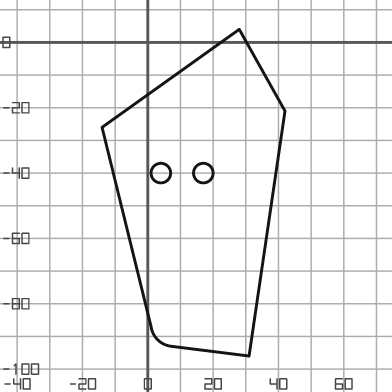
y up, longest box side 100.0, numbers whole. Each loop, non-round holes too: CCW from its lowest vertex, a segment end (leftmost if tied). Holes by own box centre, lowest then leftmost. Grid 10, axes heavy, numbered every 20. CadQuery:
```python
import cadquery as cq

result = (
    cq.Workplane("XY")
    .moveTo(31.0, -96.0)
    .lineTo(42.0, -21.0)
    .lineTo(28.0, 4.0)
    .lineTo(-14.0, -26.0)
    .lineTo(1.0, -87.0)
    .threePointArc((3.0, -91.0), (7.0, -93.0))
    .close()
    .moveTo(4.0, -40.0)
    .circle(3.0)
    .moveTo(17.0, -40.0)
    .circle(3.0)
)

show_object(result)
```